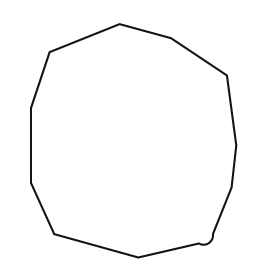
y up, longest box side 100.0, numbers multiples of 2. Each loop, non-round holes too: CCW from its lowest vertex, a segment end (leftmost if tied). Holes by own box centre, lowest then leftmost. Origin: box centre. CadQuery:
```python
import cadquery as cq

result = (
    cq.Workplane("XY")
    .moveTo(2.0, -50.0)
    .lineTo(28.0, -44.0)
    .threePointArc((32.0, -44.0), (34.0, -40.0))
    .lineTo(42.0, -20.0)
    .lineTo(44.0, -2.0)
    .lineTo(40.0, 28.0)
    .lineTo(16.0, 44.0)
    .lineTo(-6.0, 50.0)
    .lineTo(-36.0, 38.0)
    .lineTo(-44.0, 14.0)
    .lineTo(-44.0, -18.0)
    .lineTo(-34.0, -40.0)
    .close()
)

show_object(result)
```